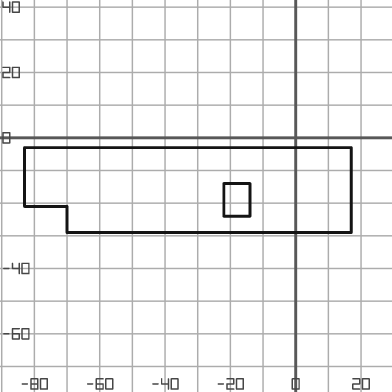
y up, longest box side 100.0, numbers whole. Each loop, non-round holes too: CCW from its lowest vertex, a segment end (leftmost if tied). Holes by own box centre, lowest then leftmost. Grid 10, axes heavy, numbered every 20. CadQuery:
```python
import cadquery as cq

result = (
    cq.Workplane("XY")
    .moveTo(-70.0, -29.0)
    .lineTo(17.0, -29.0)
    .lineTo(17.0, -3.0)
    .lineTo(-83.0, -3.0)
    .lineTo(-83.0, -21.0)
    .lineTo(-70.0, -21.0)
    .close()
    .moveTo(-22.0, -24.0)
    .lineTo(-14.0, -24.0)
    .lineTo(-14.0, -14.0)
    .lineTo(-22.0, -14.0)
    .close()
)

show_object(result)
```